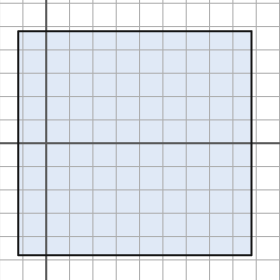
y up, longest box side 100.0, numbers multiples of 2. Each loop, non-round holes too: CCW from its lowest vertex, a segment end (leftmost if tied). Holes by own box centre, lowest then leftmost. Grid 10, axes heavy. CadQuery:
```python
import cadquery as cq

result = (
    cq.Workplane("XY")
    .moveTo(-12.0, -48.0)
    .lineTo(88.0, -48.0)
    .lineTo(88.0, 48.0)
    .lineTo(-12.0, 48.0)
    .close()
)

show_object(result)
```